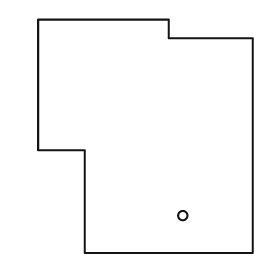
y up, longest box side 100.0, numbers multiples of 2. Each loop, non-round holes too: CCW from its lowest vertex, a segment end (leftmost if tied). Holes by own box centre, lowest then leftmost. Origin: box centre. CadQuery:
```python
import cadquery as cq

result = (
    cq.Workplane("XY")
    .moveTo(-26.0, -50.0)
    .lineTo(46.0, -50.0)
    .lineTo(46.0, 42.0)
    .lineTo(10.0, 42.0)
    .lineTo(10.0, 50.0)
    .lineTo(-46.0, 50.0)
    .lineTo(-46.0, -6.0)
    .lineTo(-26.0, -6.0)
    .close()
    .moveTo(16.0, -34.0)
    .circle(2.0)
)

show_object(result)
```